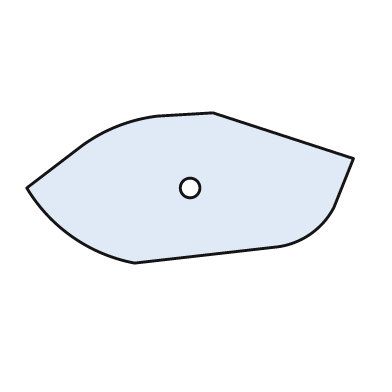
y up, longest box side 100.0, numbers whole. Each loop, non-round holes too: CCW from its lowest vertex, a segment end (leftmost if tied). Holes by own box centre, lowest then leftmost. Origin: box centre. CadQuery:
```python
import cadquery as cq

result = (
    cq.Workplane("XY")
    .moveTo(-17.0, -23.0)
    .lineTo(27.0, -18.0)
    .threePointArc((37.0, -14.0), (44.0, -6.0))
    .lineTo(50.0, 9.0)
    .lineTo(7.0, 23.0)
    .lineTo(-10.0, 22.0)
    .threePointArc((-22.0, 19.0), (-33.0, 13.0))
    .lineTo(-50.0, 0.0)
    .threePointArc((-36.0, -15.0), (-17.0, -23.0))
    .close()
    .moveTo(0.0, 0.0)
    .circle(3.0)
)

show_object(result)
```